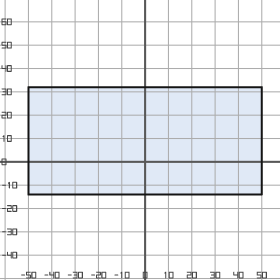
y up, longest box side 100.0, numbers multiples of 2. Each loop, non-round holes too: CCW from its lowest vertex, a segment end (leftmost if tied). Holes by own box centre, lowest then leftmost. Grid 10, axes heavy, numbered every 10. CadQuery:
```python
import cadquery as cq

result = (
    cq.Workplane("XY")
    .moveTo(-50.0, -14.0)
    .lineTo(50.0, -14.0)
    .lineTo(50.0, 32.0)
    .lineTo(-50.0, 32.0)
    .close()
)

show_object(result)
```